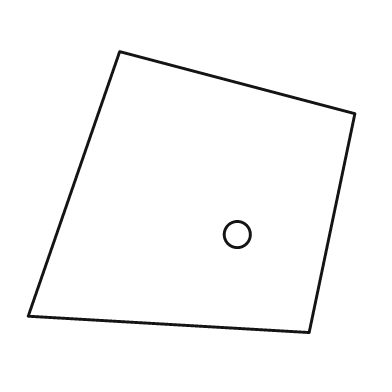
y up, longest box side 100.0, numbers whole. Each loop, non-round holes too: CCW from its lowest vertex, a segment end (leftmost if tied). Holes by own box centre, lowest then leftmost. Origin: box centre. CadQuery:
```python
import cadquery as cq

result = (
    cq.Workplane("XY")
    .moveTo(36.0, -43.0)
    .lineTo(50.0, 24.0)
    .lineTo(-22.0, 43.0)
    .lineTo(-50.0, -38.0)
    .close()
    .moveTo(14.0, -13.0)
    .circle(4.0)
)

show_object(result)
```